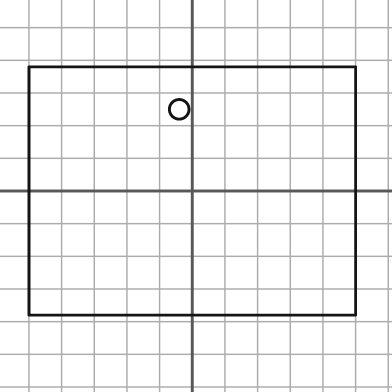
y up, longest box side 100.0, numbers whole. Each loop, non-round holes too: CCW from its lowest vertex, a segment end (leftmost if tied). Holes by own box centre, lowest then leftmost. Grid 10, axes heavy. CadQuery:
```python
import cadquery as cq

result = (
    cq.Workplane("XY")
    .moveTo(-50.0, -38.0)
    .lineTo(50.0, -38.0)
    .lineTo(50.0, 38.0)
    .lineTo(-50.0, 38.0)
    .close()
    .moveTo(-4.0, 25.0)
    .circle(3.0)
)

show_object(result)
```